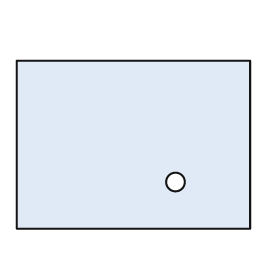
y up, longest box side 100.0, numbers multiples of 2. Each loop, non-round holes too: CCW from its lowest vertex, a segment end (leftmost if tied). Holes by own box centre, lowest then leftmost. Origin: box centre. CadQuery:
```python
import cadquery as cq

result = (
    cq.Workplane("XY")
    .moveTo(-50.0, -36.0)
    .lineTo(50.0, -36.0)
    .lineTo(50.0, 36.0)
    .lineTo(-50.0, 36.0)
    .close()
    .moveTo(18.0, -16.0)
    .circle(4.0)
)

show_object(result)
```